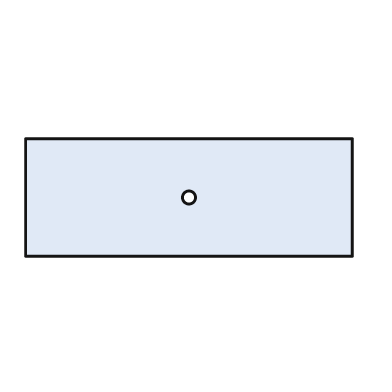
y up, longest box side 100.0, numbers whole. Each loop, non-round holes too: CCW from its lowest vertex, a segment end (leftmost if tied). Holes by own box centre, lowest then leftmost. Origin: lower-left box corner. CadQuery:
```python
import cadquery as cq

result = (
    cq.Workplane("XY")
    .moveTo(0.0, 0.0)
    .lineTo(100.0, 0.0)
    .lineTo(100.0, 36.0)
    .lineTo(0.0, 36.0)
    .close()
    .moveTo(50.0, 18.0)
    .circle(2.0)
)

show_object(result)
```